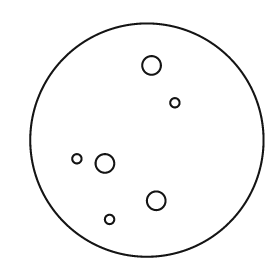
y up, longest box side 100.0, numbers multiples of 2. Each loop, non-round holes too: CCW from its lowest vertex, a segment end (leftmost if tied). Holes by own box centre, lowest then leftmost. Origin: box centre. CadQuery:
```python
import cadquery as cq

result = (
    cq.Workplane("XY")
    .moveTo(0.0, 0.0)
    .circle(50.0)
    .moveTo(-16.0, -34.0)
    .circle(2.0)
    .moveTo(4.0, -26.0)
    .circle(4.0)
    .moveTo(-18.0, -10.0)
    .circle(4.0)
    .moveTo(-30.0, -8.0)
    .circle(2.0)
    .moveTo(12.0, 16.0)
    .circle(2.0)
    .moveTo(2.0, 32.0)
    .circle(4.0)
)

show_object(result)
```